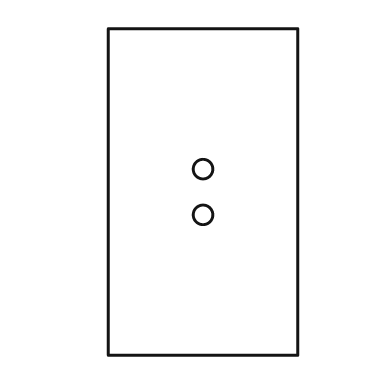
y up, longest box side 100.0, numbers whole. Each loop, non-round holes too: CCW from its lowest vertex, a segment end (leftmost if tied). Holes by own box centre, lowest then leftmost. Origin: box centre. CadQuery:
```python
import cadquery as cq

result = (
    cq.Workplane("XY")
    .moveTo(-29.0, -50.0)
    .lineTo(29.0, -50.0)
    .lineTo(29.0, 50.0)
    .lineTo(-29.0, 50.0)
    .close()
    .moveTo(0.0, -7.0)
    .circle(3.0)
    .moveTo(0.0, 7.0)
    .circle(3.0)
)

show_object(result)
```